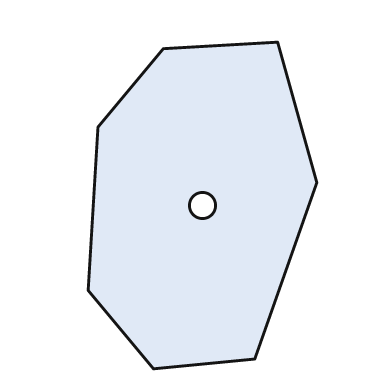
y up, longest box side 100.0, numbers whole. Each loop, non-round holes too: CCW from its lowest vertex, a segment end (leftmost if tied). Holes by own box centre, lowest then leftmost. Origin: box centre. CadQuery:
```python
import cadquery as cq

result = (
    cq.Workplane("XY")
    .moveTo(-15.0, -50.0)
    .lineTo(16.0, -47.0)
    .lineTo(35.0, 7.0)
    .lineTo(23.0, 50.0)
    .lineTo(-12.0, 48.0)
    .lineTo(-32.0, 24.0)
    .lineTo(-35.0, -26.0)
    .close()
    .moveTo(0.0, 0.0)
    .circle(4.0)
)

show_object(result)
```